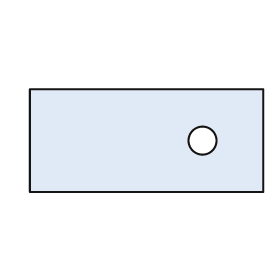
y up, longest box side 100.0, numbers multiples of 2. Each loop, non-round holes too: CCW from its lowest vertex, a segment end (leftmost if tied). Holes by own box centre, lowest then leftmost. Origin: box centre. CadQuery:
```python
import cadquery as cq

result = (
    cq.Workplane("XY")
    .moveTo(-50.0, -22.0)
    .lineTo(50.0, -22.0)
    .lineTo(50.0, 22.0)
    .lineTo(-50.0, 22.0)
    .close()
    .moveTo(24.0, 0.0)
    .circle(6.0)
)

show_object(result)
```